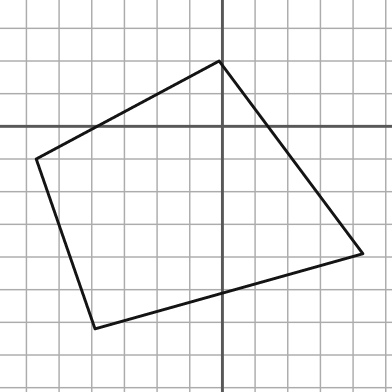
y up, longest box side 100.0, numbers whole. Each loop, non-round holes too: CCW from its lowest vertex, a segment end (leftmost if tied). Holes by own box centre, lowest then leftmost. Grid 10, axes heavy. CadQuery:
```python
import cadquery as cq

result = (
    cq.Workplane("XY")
    .moveTo(-39.0, -62.0)
    .lineTo(43.0, -39.0)
    .lineTo(-1.0, 20.0)
    .lineTo(-57.0, -10.0)
    .close()
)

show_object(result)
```